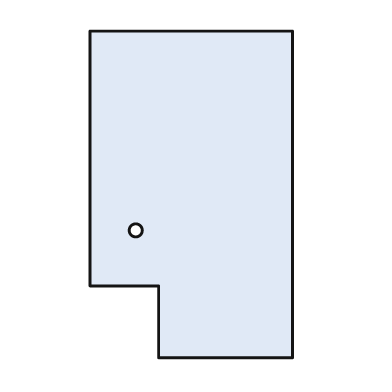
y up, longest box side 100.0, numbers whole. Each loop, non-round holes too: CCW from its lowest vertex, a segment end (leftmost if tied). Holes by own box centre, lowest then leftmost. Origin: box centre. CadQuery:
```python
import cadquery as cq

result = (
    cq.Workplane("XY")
    .moveTo(-10.0, -50.0)
    .lineTo(31.0, -50.0)
    .lineTo(31.0, 50.0)
    .lineTo(-31.0, 50.0)
    .lineTo(-31.0, -28.0)
    .lineTo(-10.0, -28.0)
    .close()
    .moveTo(-17.0, -11.0)
    .circle(2.0)
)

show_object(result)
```